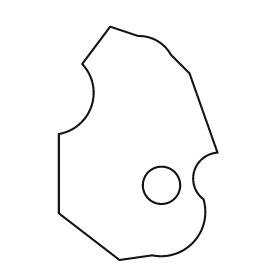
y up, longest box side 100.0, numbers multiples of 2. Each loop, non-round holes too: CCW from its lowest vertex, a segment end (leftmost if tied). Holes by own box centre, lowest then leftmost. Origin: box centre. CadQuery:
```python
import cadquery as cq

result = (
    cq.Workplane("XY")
    .moveTo(-8.0, -50.0)
    .lineTo(6.0, -48.0)
    .threePointArc((24.0, -42.0), (28.0, -24.0))
    .threePointArc((24.0, -12.0), (34.0, -4.0))
    .lineTo(22.0, 30.0)
    .lineTo(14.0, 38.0)
    .threePointArc((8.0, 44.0), (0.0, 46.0))
    .lineTo(-12.0, 50.0)
    .lineTo(-24.0, 34.0)
    .threePointArc((-20.0, 16.0), (-34.0, 4.0))
    .lineTo(-34.0, -30.0)
    .close()
    .moveTo(10.0, -18.0)
    .circle(8.0)
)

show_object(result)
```